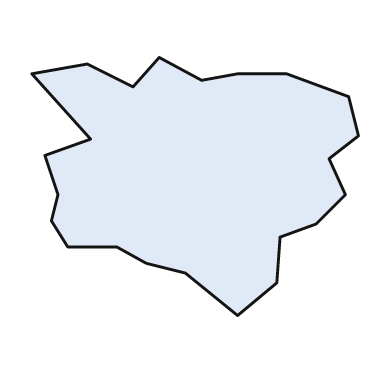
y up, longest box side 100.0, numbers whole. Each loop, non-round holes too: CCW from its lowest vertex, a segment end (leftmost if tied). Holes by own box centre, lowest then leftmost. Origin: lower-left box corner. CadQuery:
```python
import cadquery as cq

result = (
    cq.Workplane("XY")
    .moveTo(63.0, 0.0)
    .lineTo(75.0, 10.0)
    .lineTo(76.0, 24.0)
    .lineTo(87.0, 28.0)
    .lineTo(96.0, 37.0)
    .lineTo(91.0, 48.0)
    .lineTo(100.0, 55.0)
    .lineTo(97.0, 67.0)
    .lineTo(78.0, 74.0)
    .lineTo(63.0, 74.0)
    .lineTo(52.0, 72.0)
    .lineTo(39.0, 79.0)
    .lineTo(31.0, 70.0)
    .lineTo(17.0, 77.0)
    .lineTo(0.0, 74.0)
    .lineTo(18.0, 54.0)
    .lineTo(4.0, 49.0)
    .lineTo(8.0, 37.0)
    .lineTo(6.0, 29.0)
    .lineTo(11.0, 21.0)
    .lineTo(26.0, 21.0)
    .lineTo(35.0, 16.0)
    .lineTo(47.0, 13.0)
    .close()
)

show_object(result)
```